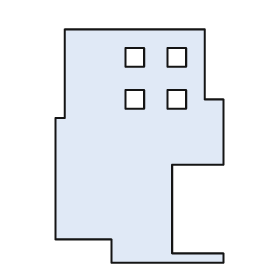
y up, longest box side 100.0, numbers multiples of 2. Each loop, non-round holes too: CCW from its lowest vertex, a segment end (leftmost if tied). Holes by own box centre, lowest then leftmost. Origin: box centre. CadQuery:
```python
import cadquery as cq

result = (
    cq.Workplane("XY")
    .moveTo(-12.0, -50.0)
    .lineTo(36.0, -50.0)
    .lineTo(36.0, -46.0)
    .lineTo(14.0, -46.0)
    .lineTo(14.0, -8.0)
    .lineTo(36.0, -8.0)
    .lineTo(36.0, 20.0)
    .lineTo(28.0, 20.0)
    .lineTo(28.0, 50.0)
    .lineTo(-32.0, 50.0)
    .lineTo(-32.0, 12.0)
    .lineTo(-36.0, 12.0)
    .lineTo(-36.0, -40.0)
    .lineTo(-12.0, -40.0)
    .close()
    .moveTo(-6.0, 16.0)
    .lineTo(2.0, 16.0)
    .lineTo(2.0, 24.0)
    .lineTo(-6.0, 24.0)
    .close()
    .moveTo(12.0, 16.0)
    .lineTo(20.0, 16.0)
    .lineTo(20.0, 24.0)
    .lineTo(12.0, 24.0)
    .close()
    .moveTo(-6.0, 34.0)
    .lineTo(2.0, 34.0)
    .lineTo(2.0, 42.0)
    .lineTo(-6.0, 42.0)
    .close()
    .moveTo(12.0, 34.0)
    .lineTo(20.0, 34.0)
    .lineTo(20.0, 42.0)
    .lineTo(12.0, 42.0)
    .close()
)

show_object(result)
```